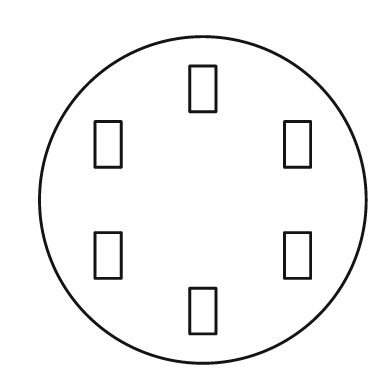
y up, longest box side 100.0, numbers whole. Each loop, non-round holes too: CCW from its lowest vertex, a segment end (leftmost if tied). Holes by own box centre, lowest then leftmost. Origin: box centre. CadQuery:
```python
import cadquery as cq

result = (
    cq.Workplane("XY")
    .moveTo(0.0, 0.0)
    .circle(50.0)
    .moveTo(-4.0, -41.0)
    .lineTo(4.0, -41.0)
    .lineTo(4.0, -27.0)
    .lineTo(-4.0, -27.0)
    .close()
    .moveTo(-33.0, -24.0)
    .lineTo(-25.0, -24.0)
    .lineTo(-25.0, -10.0)
    .lineTo(-33.0, -10.0)
    .close()
    .moveTo(25.0, -24.0)
    .lineTo(33.0, -24.0)
    .lineTo(33.0, -10.0)
    .lineTo(25.0, -10.0)
    .close()
    .moveTo(-33.0, 10.0)
    .lineTo(-25.0, 10.0)
    .lineTo(-25.0, 24.0)
    .lineTo(-33.0, 24.0)
    .close()
    .moveTo(25.0, 10.0)
    .lineTo(33.0, 10.0)
    .lineTo(33.0, 24.0)
    .lineTo(25.0, 24.0)
    .close()
    .moveTo(-4.0, 27.0)
    .lineTo(4.0, 27.0)
    .lineTo(4.0, 41.0)
    .lineTo(-4.0, 41.0)
    .close()
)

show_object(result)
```